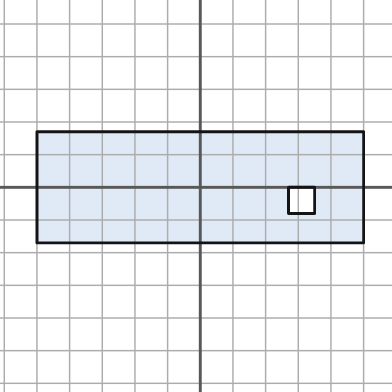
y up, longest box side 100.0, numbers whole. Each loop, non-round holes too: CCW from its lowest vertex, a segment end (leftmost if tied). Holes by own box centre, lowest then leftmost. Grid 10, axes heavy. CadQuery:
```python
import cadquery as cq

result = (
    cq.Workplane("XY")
    .moveTo(-50.0, -17.0)
    .lineTo(50.0, -17.0)
    .lineTo(50.0, 17.0)
    .lineTo(-50.0, 17.0)
    .close()
    .moveTo(27.0, -8.0)
    .lineTo(35.0, -8.0)
    .lineTo(35.0, 0.0)
    .lineTo(27.0, 0.0)
    .close()
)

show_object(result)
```